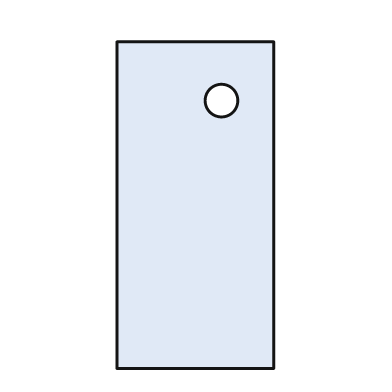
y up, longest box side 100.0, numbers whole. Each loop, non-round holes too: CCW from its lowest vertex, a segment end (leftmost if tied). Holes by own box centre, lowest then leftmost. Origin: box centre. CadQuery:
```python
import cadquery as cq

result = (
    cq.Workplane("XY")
    .moveTo(-24.0, -50.0)
    .lineTo(24.0, -50.0)
    .lineTo(24.0, 50.0)
    .lineTo(-24.0, 50.0)
    .close()
    .moveTo(8.0, 32.0)
    .circle(5.0)
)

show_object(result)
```